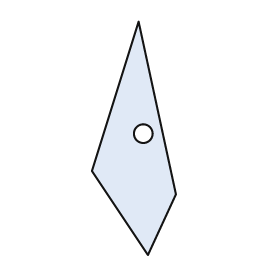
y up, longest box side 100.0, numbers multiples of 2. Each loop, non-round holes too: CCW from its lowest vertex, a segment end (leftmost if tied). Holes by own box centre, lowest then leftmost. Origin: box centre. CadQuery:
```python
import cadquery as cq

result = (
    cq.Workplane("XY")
    .moveTo(6.0, -50.0)
    .lineTo(18.0, -24.0)
    .lineTo(2.0, 50.0)
    .lineTo(-18.0, -14.0)
    .close()
    .moveTo(4.0, 2.0)
    .circle(4.0)
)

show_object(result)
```